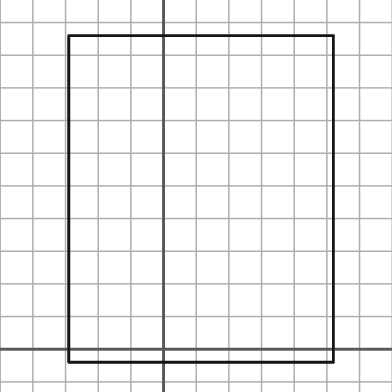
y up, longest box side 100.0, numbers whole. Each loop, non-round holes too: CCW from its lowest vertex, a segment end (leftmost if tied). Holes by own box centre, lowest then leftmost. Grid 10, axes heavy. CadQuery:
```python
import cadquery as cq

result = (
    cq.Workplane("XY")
    .moveTo(-29.0, -4.0)
    .lineTo(52.0, -4.0)
    .lineTo(52.0, 96.0)
    .lineTo(-29.0, 96.0)
    .close()
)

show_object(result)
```